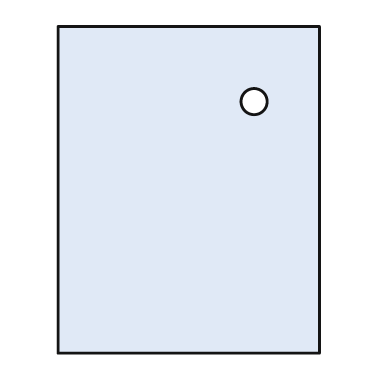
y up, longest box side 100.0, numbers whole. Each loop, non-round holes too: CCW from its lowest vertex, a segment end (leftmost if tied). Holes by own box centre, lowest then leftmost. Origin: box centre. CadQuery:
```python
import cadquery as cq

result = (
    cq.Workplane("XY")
    .moveTo(-40.0, -50.0)
    .lineTo(40.0, -50.0)
    .lineTo(40.0, 50.0)
    .lineTo(-40.0, 50.0)
    .close()
    .moveTo(20.0, 27.0)
    .circle(4.0)
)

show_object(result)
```